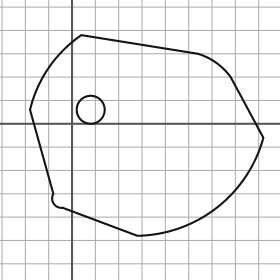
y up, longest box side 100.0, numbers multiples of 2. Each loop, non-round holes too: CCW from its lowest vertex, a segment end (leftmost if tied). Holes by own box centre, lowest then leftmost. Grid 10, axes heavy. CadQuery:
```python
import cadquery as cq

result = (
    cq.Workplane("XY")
    .moveTo(28.0, -48.0)
    .threePointArc((62.0, -36.0), (82.0, -6.0))
    .lineTo(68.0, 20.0)
    .threePointArc((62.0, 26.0), (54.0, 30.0))
    .lineTo(4.0, 38.0)
    .threePointArc((-10.0, 24.0), (-18.0, 6.0))
    .lineTo(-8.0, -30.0)
    .threePointArc((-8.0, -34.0), (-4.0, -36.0))
    .close()
    .moveTo(8.0, 6.0)
    .circle(6.0)
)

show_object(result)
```